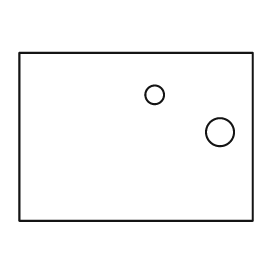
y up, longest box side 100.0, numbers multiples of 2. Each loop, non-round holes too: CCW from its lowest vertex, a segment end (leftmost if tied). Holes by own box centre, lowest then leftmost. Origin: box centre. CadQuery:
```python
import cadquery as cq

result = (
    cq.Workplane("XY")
    .moveTo(-50.0, -36.0)
    .lineTo(50.0, -36.0)
    .lineTo(50.0, 36.0)
    .lineTo(-50.0, 36.0)
    .close()
    .moveTo(36.0, 2.0)
    .circle(6.0)
    .moveTo(8.0, 18.0)
    .circle(4.0)
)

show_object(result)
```